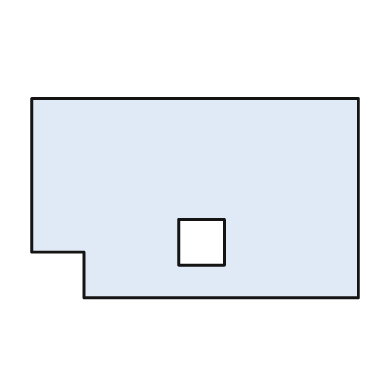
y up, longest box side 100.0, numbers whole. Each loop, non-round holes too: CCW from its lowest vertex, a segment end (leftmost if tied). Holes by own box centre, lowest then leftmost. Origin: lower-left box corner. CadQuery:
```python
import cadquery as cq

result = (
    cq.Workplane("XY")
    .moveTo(16.0, 0.0)
    .lineTo(100.0, 0.0)
    .lineTo(100.0, 61.0)
    .lineTo(0.0, 61.0)
    .lineTo(0.0, 14.0)
    .lineTo(16.0, 14.0)
    .close()
    .moveTo(45.0, 10.0)
    .lineTo(59.0, 10.0)
    .lineTo(59.0, 24.0)
    .lineTo(45.0, 24.0)
    .close()
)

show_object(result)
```